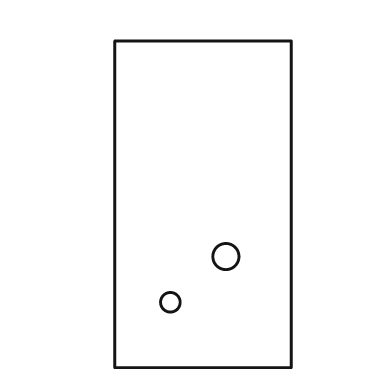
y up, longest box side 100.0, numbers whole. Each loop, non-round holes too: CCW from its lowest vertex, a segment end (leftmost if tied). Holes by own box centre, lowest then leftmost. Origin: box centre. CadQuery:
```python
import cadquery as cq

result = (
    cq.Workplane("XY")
    .moveTo(-27.0, -50.0)
    .lineTo(27.0, -50.0)
    .lineTo(27.0, 50.0)
    .lineTo(-27.0, 50.0)
    .close()
    .moveTo(-10.0, -30.0)
    .circle(3.0)
    .moveTo(7.0, -16.0)
    .circle(4.0)
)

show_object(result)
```